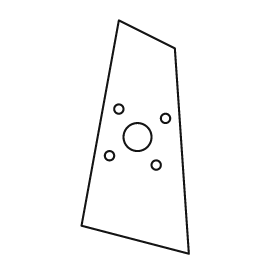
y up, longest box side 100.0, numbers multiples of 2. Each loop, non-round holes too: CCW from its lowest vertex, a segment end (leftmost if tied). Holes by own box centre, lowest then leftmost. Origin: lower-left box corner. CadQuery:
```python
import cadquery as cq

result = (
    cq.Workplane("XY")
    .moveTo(46.0, 0.0)
    .lineTo(40.0, 88.0)
    .lineTo(16.0, 100.0)
    .lineTo(0.0, 12.0)
    .close()
    .moveTo(32.0, 38.0)
    .circle(2.0)
    .moveTo(12.0, 42.0)
    .circle(2.0)
    .moveTo(24.0, 50.0)
    .circle(6.0)
    .moveTo(36.0, 58.0)
    .circle(2.0)
    .moveTo(16.0, 62.0)
    .circle(2.0)
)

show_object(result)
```